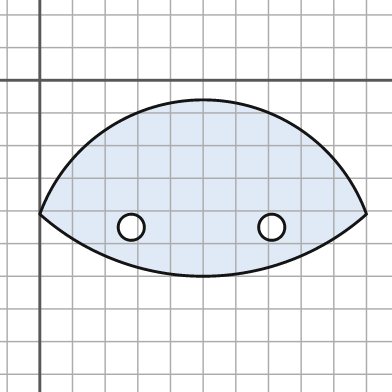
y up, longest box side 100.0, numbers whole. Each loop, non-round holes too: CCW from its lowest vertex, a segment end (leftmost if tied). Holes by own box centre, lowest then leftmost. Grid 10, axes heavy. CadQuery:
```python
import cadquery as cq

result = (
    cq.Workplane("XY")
    .moveTo(0.0, -41.0)
    .threePointArc((50.0, -60.0), (100.0, -41.0))
    .threePointArc((50.0, -6.0), (0.0, -41.0))
    .close()
    .moveTo(28.0, -45.0)
    .circle(4.0)
    .moveTo(71.0, -45.0)
    .circle(4.0)
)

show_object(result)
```